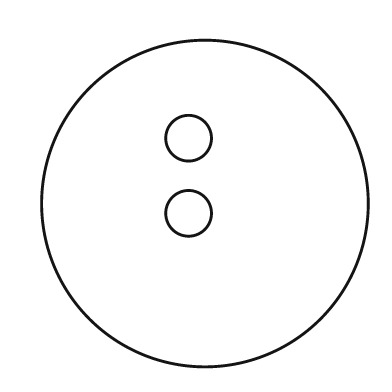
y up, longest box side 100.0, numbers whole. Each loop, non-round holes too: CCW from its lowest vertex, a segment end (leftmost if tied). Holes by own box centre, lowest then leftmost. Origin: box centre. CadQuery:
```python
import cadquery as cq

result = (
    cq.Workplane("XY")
    .moveTo(0.0, 0.0)
    .circle(50.0)
    .moveTo(-5.0, -3.0)
    .circle(7.0)
    .moveTo(-5.0, 20.0)
    .circle(7.0)
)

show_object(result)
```